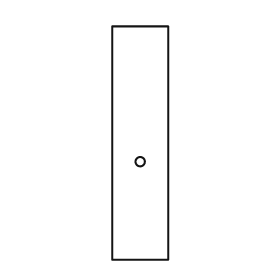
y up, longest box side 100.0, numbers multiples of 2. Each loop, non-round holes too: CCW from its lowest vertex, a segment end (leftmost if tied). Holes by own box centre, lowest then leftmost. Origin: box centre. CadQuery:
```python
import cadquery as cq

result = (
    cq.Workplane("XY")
    .moveTo(-12.0, -50.0)
    .lineTo(12.0, -50.0)
    .lineTo(12.0, 50.0)
    .lineTo(-12.0, 50.0)
    .close()
    .moveTo(0.0, -8.0)
    .circle(2.0)
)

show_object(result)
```